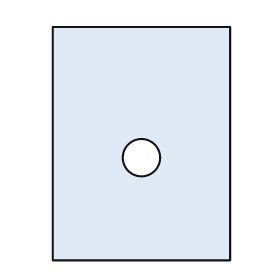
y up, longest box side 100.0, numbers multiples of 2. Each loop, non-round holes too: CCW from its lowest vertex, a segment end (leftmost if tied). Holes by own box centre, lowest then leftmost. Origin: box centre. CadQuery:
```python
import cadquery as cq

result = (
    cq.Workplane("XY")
    .moveTo(-38.0, -50.0)
    .lineTo(38.0, -50.0)
    .lineTo(38.0, 50.0)
    .lineTo(-38.0, 50.0)
    .close()
    .moveTo(0.0, -6.0)
    .circle(8.0)
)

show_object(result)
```